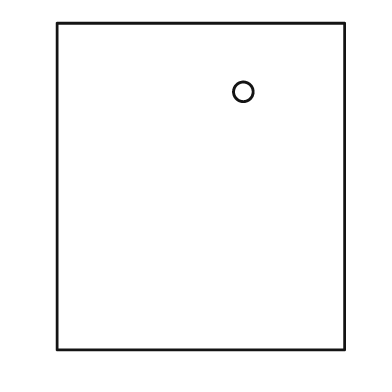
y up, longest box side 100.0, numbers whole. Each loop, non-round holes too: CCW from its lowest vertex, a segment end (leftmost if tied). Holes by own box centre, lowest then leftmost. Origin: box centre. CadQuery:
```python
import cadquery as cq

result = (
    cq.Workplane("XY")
    .moveTo(-44.0, -50.0)
    .lineTo(44.0, -50.0)
    .lineTo(44.0, 50.0)
    .lineTo(-44.0, 50.0)
    .close()
    .moveTo(13.0, 29.0)
    .circle(3.0)
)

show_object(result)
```